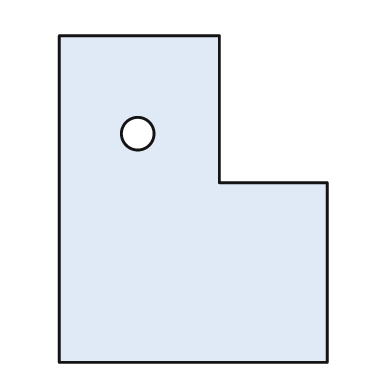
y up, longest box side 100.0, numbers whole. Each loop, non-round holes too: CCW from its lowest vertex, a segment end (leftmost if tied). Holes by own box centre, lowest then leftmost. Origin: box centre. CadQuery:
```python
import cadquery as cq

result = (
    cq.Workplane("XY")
    .moveTo(-41.0, -50.0)
    .lineTo(41.0, -50.0)
    .lineTo(41.0, 5.0)
    .lineTo(8.0, 5.0)
    .lineTo(8.0, 50.0)
    .lineTo(-41.0, 50.0)
    .close()
    .moveTo(-17.0, 20.0)
    .circle(5.0)
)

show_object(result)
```